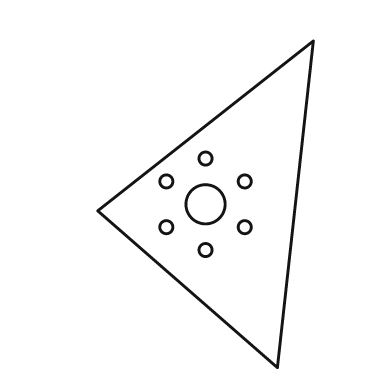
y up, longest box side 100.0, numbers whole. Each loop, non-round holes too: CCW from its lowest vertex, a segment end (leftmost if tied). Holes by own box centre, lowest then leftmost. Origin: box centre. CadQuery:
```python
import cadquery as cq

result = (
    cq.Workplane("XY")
    .moveTo(22.0, -50.0)
    .lineTo(33.0, 50.0)
    .lineTo(-33.0, -2.0)
    .close()
    .moveTo(0.0, -14.0)
    .circle(2.0)
    .moveTo(-12.0, -7.0)
    .circle(2.0)
    .moveTo(12.0, -7.0)
    .circle(2.0)
    .moveTo(0.0, 0.0)
    .circle(6.0)
    .moveTo(-12.0, 7.0)
    .circle(2.0)
    .moveTo(12.0, 7.0)
    .circle(2.0)
    .moveTo(0.0, 14.0)
    .circle(2.0)
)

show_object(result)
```